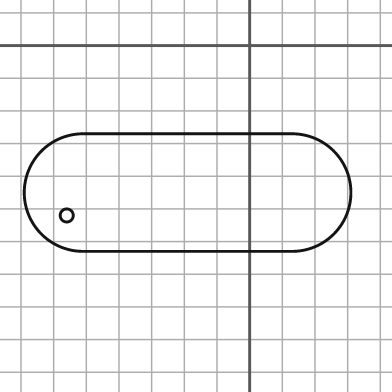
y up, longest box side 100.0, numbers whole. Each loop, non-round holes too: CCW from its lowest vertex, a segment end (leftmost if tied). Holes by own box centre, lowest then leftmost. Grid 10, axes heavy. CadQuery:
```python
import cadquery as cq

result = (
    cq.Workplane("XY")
    .moveTo(-51.0, -63.0)
    .lineTo(13.0, -63.0)
    .threePointArc((31.0, -45.0), (13.0, -27.0))
    .lineTo(-51.0, -27.0)
    .threePointArc((-69.0, -45.0), (-51.0, -63.0))
    .close()
    .moveTo(-56.0, -52.0)
    .circle(2.0)
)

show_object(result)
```